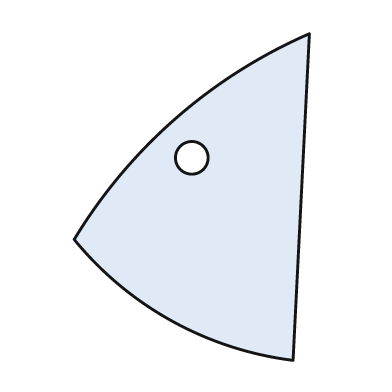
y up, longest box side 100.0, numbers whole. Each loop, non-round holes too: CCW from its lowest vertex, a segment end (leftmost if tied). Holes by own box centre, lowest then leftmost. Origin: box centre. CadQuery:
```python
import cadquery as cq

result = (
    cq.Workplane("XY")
    .moveTo(31.0, -50.0)
    .lineTo(36.0, 50.0)
    .threePointArc((-5.0, 24.0), (-36.0, -13.0))
    .threePointArc((-6.0, -38.0), (31.0, -50.0))
    .close()
    .moveTo(0.0, 12.0)
    .circle(5.0)
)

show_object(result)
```